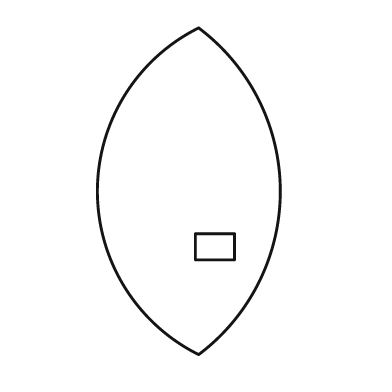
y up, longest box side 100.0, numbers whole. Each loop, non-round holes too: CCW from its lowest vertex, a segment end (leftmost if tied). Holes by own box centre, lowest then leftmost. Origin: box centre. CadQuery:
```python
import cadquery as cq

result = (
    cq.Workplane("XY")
    .moveTo(3.0, -50.0)
    .threePointArc((28.0, 0.0), (3.0, 50.0))
    .threePointArc((-28.0, 0.0), (3.0, -50.0))
    .close()
    .moveTo(2.0, -21.0)
    .lineTo(14.0, -21.0)
    .lineTo(14.0, -13.0)
    .lineTo(2.0, -13.0)
    .close()
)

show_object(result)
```